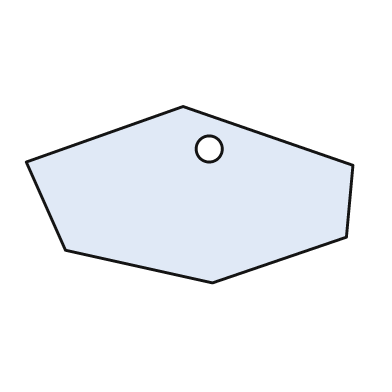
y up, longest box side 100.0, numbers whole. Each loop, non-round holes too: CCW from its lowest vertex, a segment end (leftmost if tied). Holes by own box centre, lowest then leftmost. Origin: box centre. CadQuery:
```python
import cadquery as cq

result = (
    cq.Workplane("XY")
    .moveTo(7.0, -27.0)
    .lineTo(48.0, -13.0)
    .lineTo(50.0, 9.0)
    .lineTo(-2.0, 27.0)
    .lineTo(-50.0, 10.0)
    .lineTo(-38.0, -17.0)
    .close()
    .moveTo(6.0, 14.0)
    .circle(4.0)
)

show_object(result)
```